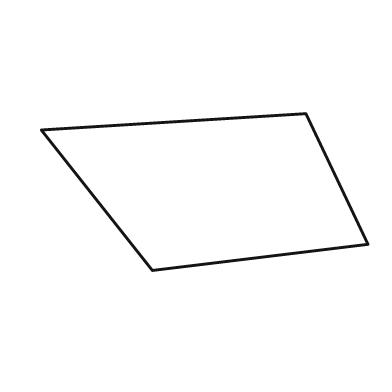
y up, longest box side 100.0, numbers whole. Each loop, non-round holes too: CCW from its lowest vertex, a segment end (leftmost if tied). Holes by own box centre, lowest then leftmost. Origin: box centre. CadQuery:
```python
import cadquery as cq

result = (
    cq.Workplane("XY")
    .moveTo(-16.0, -24.0)
    .lineTo(50.0, -16.0)
    .lineTo(31.0, 24.0)
    .lineTo(-50.0, 19.0)
    .close()
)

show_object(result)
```